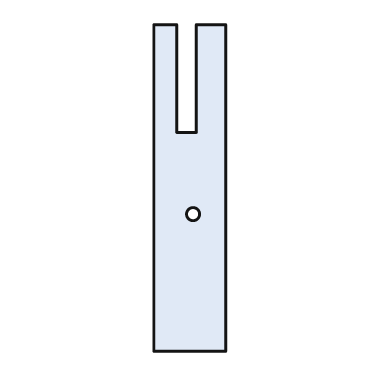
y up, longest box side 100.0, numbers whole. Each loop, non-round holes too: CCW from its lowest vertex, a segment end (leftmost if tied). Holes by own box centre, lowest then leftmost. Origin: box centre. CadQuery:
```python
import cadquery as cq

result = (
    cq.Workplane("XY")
    .moveTo(-11.0, -50.0)
    .lineTo(11.0, -50.0)
    .lineTo(11.0, 50.0)
    .lineTo(2.0, 50.0)
    .lineTo(2.0, 17.0)
    .lineTo(-4.0, 17.0)
    .lineTo(-4.0, 50.0)
    .lineTo(-11.0, 50.0)
    .close()
    .moveTo(1.0, -8.0)
    .circle(2.0)
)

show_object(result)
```